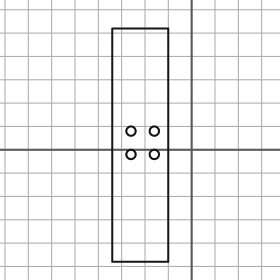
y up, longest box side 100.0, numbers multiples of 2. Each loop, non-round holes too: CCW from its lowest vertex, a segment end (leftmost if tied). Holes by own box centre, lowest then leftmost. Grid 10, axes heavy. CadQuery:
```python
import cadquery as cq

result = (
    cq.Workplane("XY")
    .moveTo(-34.0, -48.0)
    .lineTo(-10.0, -48.0)
    .lineTo(-10.0, 52.0)
    .lineTo(-34.0, 52.0)
    .close()
    .moveTo(-26.0, -2.0)
    .circle(2.0)
    .moveTo(-16.0, -2.0)
    .circle(2.0)
    .moveTo(-26.0, 8.0)
    .circle(2.0)
    .moveTo(-16.0, 8.0)
    .circle(2.0)
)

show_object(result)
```